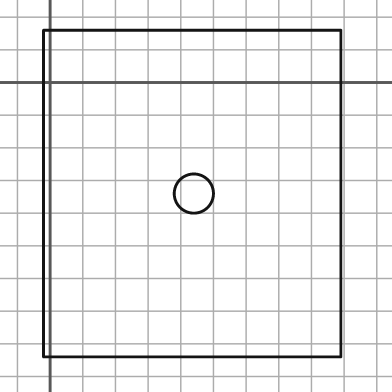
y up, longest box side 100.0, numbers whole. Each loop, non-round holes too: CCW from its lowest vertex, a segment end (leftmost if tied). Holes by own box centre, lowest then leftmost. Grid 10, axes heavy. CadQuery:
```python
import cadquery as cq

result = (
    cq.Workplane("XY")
    .moveTo(-2.0, -84.0)
    .lineTo(89.0, -84.0)
    .lineTo(89.0, 16.0)
    .lineTo(-2.0, 16.0)
    .close()
    .moveTo(44.0, -34.0)
    .circle(6.0)
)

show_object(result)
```